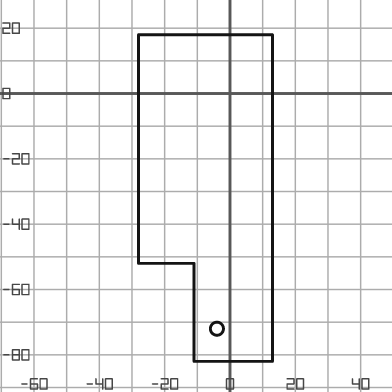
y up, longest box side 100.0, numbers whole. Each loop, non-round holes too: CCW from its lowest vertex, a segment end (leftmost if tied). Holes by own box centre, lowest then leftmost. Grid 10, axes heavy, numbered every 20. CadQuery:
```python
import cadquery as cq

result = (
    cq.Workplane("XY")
    .moveTo(-11.0, -82.0)
    .lineTo(13.0, -82.0)
    .lineTo(13.0, 18.0)
    .lineTo(-28.0, 18.0)
    .lineTo(-28.0, -52.0)
    .lineTo(-11.0, -52.0)
    .close()
    .moveTo(-4.0, -72.0)
    .circle(2.0)
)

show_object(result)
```